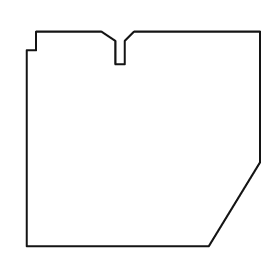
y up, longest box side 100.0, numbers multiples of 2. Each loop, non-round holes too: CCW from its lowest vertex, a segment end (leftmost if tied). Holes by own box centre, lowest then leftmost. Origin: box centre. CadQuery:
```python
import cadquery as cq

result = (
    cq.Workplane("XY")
    .moveTo(-50.0, -46.0)
    .lineTo(28.0, -46.0)
    .lineTo(50.0, -10.0)
    .lineTo(50.0, 46.0)
    .lineTo(-4.0, 46.0)
    .lineTo(-8.0, 42.0)
    .lineTo(-8.0, 32.0)
    .lineTo(-12.0, 32.0)
    .lineTo(-12.0, 42.0)
    .lineTo(-18.0, 46.0)
    .lineTo(-46.0, 46.0)
    .lineTo(-46.0, 38.0)
    .lineTo(-50.0, 38.0)
    .close()
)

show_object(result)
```